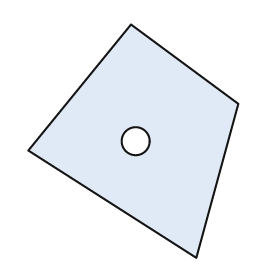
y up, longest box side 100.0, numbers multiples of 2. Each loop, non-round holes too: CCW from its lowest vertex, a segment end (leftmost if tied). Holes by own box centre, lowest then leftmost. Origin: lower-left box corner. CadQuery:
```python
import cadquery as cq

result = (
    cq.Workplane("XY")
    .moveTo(72.0, 0.0)
    .lineTo(90.0, 66.0)
    .lineTo(44.0, 100.0)
    .lineTo(0.0, 46.0)
    .close()
    .moveTo(46.0, 50.0)
    .circle(6.0)
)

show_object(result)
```